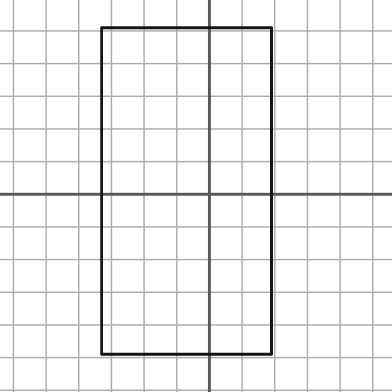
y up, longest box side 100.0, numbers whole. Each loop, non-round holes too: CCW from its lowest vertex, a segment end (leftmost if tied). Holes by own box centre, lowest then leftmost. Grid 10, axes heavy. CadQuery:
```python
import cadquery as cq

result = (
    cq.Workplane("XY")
    .moveTo(-33.0, -49.0)
    .lineTo(19.0, -49.0)
    .lineTo(19.0, 51.0)
    .lineTo(-33.0, 51.0)
    .close()
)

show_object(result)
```